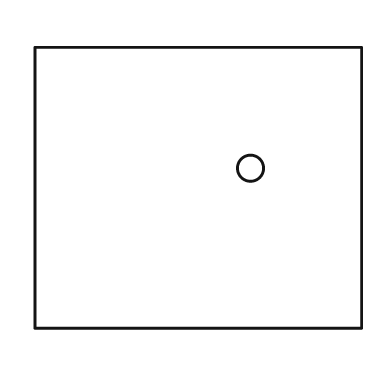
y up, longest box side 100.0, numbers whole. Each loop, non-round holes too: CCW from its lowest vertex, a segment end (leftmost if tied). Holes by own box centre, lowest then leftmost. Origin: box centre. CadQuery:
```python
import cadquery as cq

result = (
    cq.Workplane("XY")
    .moveTo(-50.0, -43.0)
    .lineTo(50.0, -43.0)
    .lineTo(50.0, 43.0)
    .lineTo(-50.0, 43.0)
    .close()
    .moveTo(16.0, 6.0)
    .circle(4.0)
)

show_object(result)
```